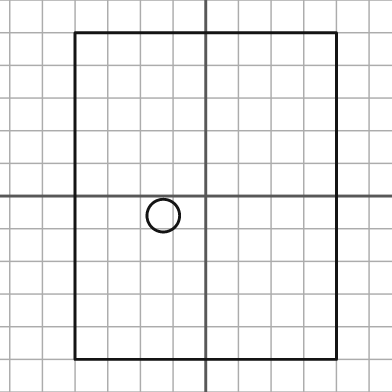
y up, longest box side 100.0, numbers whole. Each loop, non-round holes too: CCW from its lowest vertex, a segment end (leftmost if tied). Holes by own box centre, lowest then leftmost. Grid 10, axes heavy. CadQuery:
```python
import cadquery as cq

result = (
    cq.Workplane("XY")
    .moveTo(-40.0, -50.0)
    .lineTo(40.0, -50.0)
    .lineTo(40.0, 50.0)
    .lineTo(-40.0, 50.0)
    .close()
    .moveTo(-13.0, -6.0)
    .circle(5.0)
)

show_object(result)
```